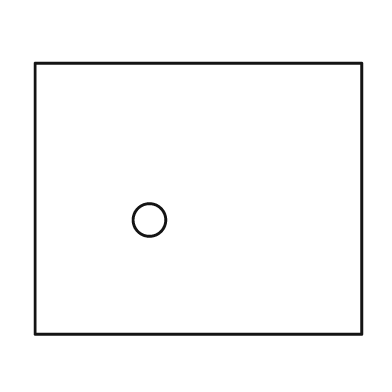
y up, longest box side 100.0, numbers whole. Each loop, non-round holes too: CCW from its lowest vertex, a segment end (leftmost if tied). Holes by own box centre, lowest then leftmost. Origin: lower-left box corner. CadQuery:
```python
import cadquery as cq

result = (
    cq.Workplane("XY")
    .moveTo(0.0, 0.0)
    .lineTo(100.0, 0.0)
    .lineTo(100.0, 83.0)
    .lineTo(0.0, 83.0)
    .close()
    .moveTo(35.0, 35.0)
    .circle(5.0)
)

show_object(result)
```